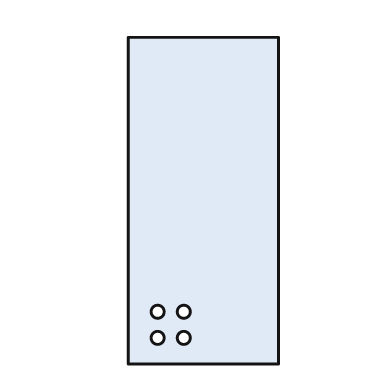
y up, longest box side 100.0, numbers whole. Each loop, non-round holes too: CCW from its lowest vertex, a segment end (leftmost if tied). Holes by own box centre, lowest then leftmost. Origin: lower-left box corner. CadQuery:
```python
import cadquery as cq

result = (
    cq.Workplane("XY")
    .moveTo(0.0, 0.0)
    .lineTo(46.0, 0.0)
    .lineTo(46.0, 100.0)
    .lineTo(0.0, 100.0)
    .close()
    .moveTo(9.0, 8.0)
    .circle(2.0)
    .moveTo(17.0, 8.0)
    .circle(2.0)
    .moveTo(9.0, 16.0)
    .circle(2.0)
    .moveTo(17.0, 16.0)
    .circle(2.0)
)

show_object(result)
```